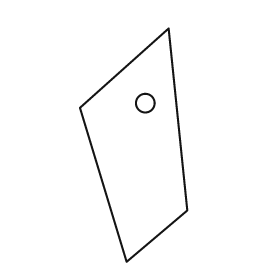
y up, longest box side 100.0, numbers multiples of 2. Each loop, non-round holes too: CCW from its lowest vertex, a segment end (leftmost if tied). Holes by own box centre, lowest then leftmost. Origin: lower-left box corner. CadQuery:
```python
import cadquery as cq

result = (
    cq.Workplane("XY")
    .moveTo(20.0, 0.0)
    .lineTo(46.0, 22.0)
    .lineTo(38.0, 100.0)
    .lineTo(0.0, 66.0)
    .close()
    .moveTo(28.0, 68.0)
    .circle(4.0)
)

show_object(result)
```